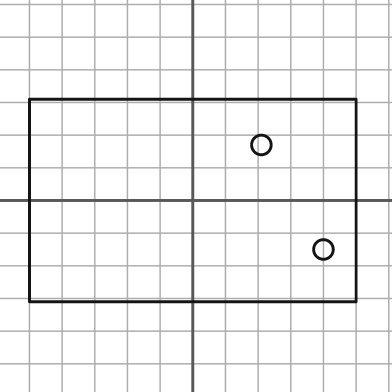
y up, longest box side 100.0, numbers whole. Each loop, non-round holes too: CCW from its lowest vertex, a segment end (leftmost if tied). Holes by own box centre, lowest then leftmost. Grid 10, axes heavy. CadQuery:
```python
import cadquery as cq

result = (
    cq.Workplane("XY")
    .moveTo(-50.0, -31.0)
    .lineTo(50.0, -31.0)
    .lineTo(50.0, 31.0)
    .lineTo(-50.0, 31.0)
    .close()
    .moveTo(40.0, -15.0)
    .circle(3.0)
    .moveTo(21.0, 17.0)
    .circle(3.0)
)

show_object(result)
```